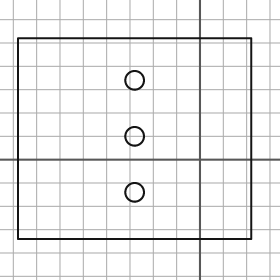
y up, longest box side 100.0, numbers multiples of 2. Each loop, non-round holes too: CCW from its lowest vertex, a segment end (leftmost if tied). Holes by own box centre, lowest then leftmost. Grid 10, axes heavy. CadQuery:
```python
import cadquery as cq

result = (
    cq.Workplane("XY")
    .moveTo(-78.0, -34.0)
    .lineTo(22.0, -34.0)
    .lineTo(22.0, 52.0)
    .lineTo(-78.0, 52.0)
    .close()
    .moveTo(-28.0, -14.0)
    .circle(4.0)
    .moveTo(-28.0, 10.0)
    .circle(4.0)
    .moveTo(-28.0, 34.0)
    .circle(4.0)
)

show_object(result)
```